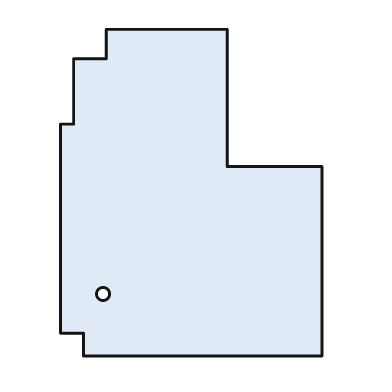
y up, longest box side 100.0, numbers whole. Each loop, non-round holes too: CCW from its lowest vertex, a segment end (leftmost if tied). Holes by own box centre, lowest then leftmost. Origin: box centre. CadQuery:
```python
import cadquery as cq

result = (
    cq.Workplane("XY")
    .moveTo(-33.0, -50.0)
    .lineTo(40.0, -50.0)
    .lineTo(40.0, 8.0)
    .lineTo(11.0, 8.0)
    .lineTo(11.0, 50.0)
    .lineTo(-26.0, 50.0)
    .lineTo(-26.0, 41.0)
    .lineTo(-36.0, 41.0)
    .lineTo(-36.0, 21.0)
    .lineTo(-40.0, 21.0)
    .lineTo(-40.0, -43.0)
    .lineTo(-33.0, -43.0)
    .close()
    .moveTo(-27.0, -31.0)
    .circle(2.0)
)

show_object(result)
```